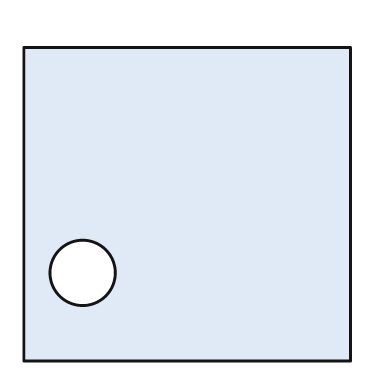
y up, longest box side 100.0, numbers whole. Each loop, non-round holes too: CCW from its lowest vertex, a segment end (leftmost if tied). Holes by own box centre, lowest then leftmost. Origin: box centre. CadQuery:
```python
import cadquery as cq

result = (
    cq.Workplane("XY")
    .moveTo(-50.0, -48.0)
    .lineTo(50.0, -48.0)
    .lineTo(50.0, 48.0)
    .lineTo(-50.0, 48.0)
    .close()
    .moveTo(-32.0, -21.0)
    .circle(10.0)
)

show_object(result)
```